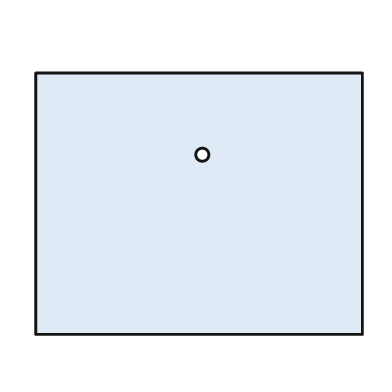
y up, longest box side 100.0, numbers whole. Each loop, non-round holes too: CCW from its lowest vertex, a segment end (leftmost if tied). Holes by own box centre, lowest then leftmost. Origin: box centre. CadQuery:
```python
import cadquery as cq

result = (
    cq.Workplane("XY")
    .moveTo(-50.0, -40.0)
    .lineTo(50.0, -40.0)
    .lineTo(50.0, 40.0)
    .lineTo(-50.0, 40.0)
    .close()
    .moveTo(1.0, 15.0)
    .circle(2.0)
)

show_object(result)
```